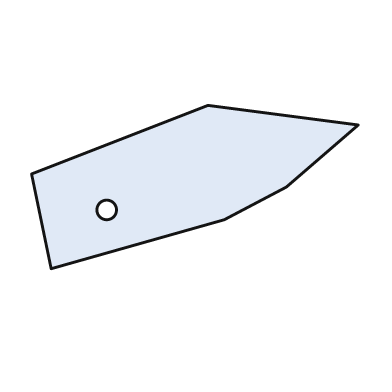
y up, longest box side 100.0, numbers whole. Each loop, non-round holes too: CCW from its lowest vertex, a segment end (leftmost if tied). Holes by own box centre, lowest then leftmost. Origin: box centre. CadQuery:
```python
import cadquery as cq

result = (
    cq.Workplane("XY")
    .moveTo(-44.0, -25.0)
    .lineTo(9.0, -10.0)
    .lineTo(28.0, 0.0)
    .lineTo(50.0, 19.0)
    .lineTo(4.0, 25.0)
    .lineTo(-50.0, 4.0)
    .close()
    .moveTo(-27.0, -7.0)
    .circle(3.0)
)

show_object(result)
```